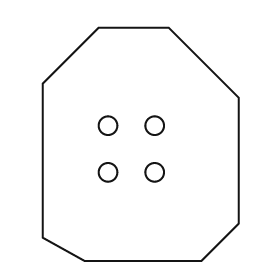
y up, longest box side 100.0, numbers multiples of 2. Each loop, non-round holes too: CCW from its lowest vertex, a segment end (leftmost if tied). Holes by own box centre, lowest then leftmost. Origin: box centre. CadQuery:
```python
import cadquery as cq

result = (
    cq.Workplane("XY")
    .moveTo(-24.0, -50.0)
    .lineTo(26.0, -50.0)
    .lineTo(42.0, -34.0)
    .lineTo(42.0, 20.0)
    .lineTo(12.0, 50.0)
    .lineTo(-18.0, 50.0)
    .lineTo(-42.0, 26.0)
    .lineTo(-42.0, -40.0)
    .close()
    .moveTo(-14.0, -12.0)
    .circle(4.0)
    .moveTo(6.0, -12.0)
    .circle(4.0)
    .moveTo(-14.0, 8.0)
    .circle(4.0)
    .moveTo(6.0, 8.0)
    .circle(4.0)
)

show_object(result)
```